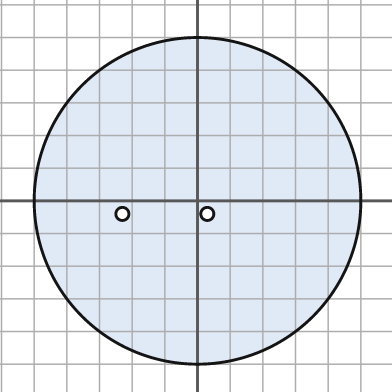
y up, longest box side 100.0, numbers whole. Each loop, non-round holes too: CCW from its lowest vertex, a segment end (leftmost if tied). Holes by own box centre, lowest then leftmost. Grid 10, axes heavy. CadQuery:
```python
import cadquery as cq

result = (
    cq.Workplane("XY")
    .moveTo(0.0, 0.0)
    .circle(50.0)
    .moveTo(-23.0, -4.0)
    .circle(2.0)
    .moveTo(3.0, -4.0)
    .circle(2.0)
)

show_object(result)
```